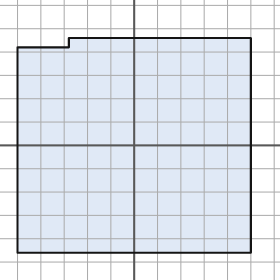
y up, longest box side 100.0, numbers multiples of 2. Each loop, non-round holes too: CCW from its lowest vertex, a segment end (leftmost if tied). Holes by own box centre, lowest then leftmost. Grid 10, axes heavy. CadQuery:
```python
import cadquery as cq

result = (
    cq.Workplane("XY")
    .moveTo(-50.0, -46.0)
    .lineTo(50.0, -46.0)
    .lineTo(50.0, 46.0)
    .lineTo(-28.0, 46.0)
    .lineTo(-28.0, 42.0)
    .lineTo(-50.0, 42.0)
    .close()
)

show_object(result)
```